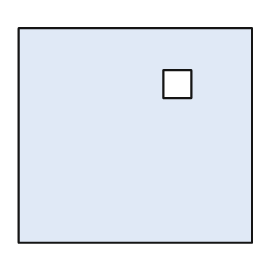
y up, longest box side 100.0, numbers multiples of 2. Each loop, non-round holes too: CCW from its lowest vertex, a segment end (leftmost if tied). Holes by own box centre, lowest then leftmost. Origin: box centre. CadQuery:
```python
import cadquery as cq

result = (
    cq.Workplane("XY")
    .moveTo(-50.0, -46.0)
    .lineTo(50.0, -46.0)
    .lineTo(50.0, 46.0)
    .lineTo(-50.0, 46.0)
    .close()
    .moveTo(12.0, 16.0)
    .lineTo(24.0, 16.0)
    .lineTo(24.0, 28.0)
    .lineTo(12.0, 28.0)
    .close()
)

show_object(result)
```